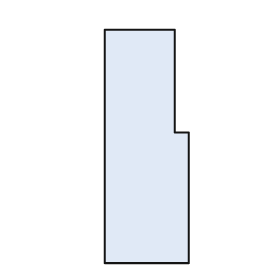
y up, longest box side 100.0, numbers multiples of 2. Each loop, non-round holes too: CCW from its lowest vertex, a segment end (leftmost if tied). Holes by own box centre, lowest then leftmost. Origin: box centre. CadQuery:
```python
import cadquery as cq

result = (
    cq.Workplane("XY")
    .moveTo(-18.0, -50.0)
    .lineTo(18.0, -50.0)
    .lineTo(18.0, 6.0)
    .lineTo(12.0, 6.0)
    .lineTo(12.0, 50.0)
    .lineTo(-18.0, 50.0)
    .close()
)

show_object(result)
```